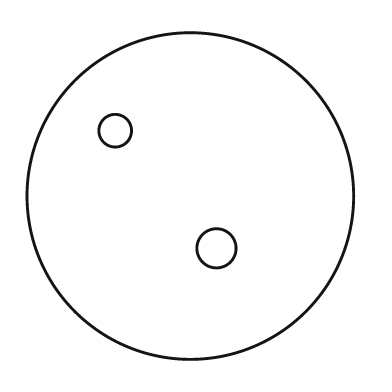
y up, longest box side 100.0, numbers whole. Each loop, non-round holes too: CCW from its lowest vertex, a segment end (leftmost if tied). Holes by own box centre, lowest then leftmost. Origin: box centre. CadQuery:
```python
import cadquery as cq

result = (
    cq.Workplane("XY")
    .moveTo(0.0, 0.0)
    .circle(50.0)
    .moveTo(8.0, -16.0)
    .circle(6.0)
    .moveTo(-23.0, 20.0)
    .circle(5.0)
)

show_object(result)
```